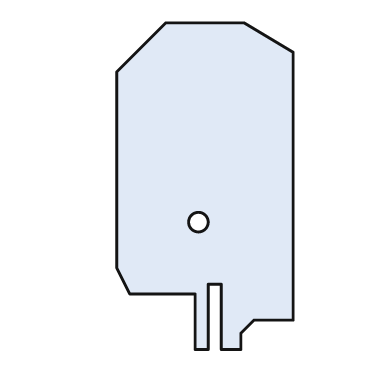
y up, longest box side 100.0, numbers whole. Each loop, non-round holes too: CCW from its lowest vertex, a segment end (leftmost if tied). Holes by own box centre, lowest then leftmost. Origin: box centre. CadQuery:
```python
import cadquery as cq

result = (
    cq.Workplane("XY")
    .moveTo(-3.0, -50.0)
    .lineTo(1.0, -50.0)
    .lineTo(1.0, -30.0)
    .lineTo(5.0, -30.0)
    .lineTo(5.0, -50.0)
    .lineTo(11.0, -50.0)
    .lineTo(11.0, -45.0)
    .lineTo(15.0, -41.0)
    .lineTo(27.0, -41.0)
    .lineTo(27.0, 41.0)
    .lineTo(12.0, 50.0)
    .lineTo(-12.0, 50.0)
    .lineTo(-27.0, 35.0)
    .lineTo(-27.0, -25.0)
    .lineTo(-23.0, -33.0)
    .lineTo(-3.0, -33.0)
    .close()
    .moveTo(-2.0, -11.0)
    .circle(3.0)
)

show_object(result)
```